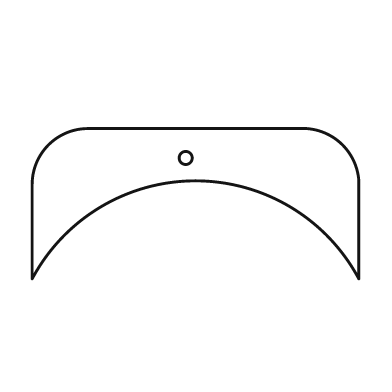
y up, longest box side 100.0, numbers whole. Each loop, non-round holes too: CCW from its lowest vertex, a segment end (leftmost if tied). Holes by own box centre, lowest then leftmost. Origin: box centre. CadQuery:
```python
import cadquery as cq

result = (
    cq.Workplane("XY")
    .moveTo(-50.0, -23.0)
    .threePointArc((0.0, 7.0), (50.0, -23.0))
    .lineTo(50.0, 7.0)
    .threePointArc((45.0, 18.0), (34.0, 23.0))
    .lineTo(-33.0, 23.0)
    .threePointArc((-45.0, 18.0), (-50.0, 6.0))
    .close()
    .moveTo(-3.0, 14.0)
    .circle(2.0)
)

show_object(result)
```